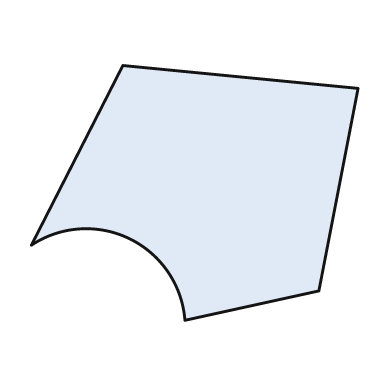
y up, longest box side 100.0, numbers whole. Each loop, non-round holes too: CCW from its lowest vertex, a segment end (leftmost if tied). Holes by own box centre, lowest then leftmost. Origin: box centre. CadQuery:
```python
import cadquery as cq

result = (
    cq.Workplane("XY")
    .moveTo(-3.0, -39.0)
    .lineTo(38.0, -30.0)
    .lineTo(50.0, 32.0)
    .lineTo(-22.0, 39.0)
    .lineTo(-50.0, -16.0)
    .threePointArc((-20.0, -14.0), (-3.0, -39.0))
    .close()
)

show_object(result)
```